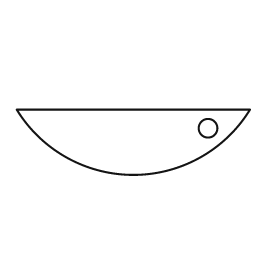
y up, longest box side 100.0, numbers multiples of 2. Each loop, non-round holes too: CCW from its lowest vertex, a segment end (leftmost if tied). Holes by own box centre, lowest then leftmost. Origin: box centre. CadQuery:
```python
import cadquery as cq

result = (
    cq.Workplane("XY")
    .moveTo(-50.0, 14.0)
    .threePointArc((0.0, -14.0), (50.0, 14.0))
    .close()
    .moveTo(32.0, 6.0)
    .circle(4.0)
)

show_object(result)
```